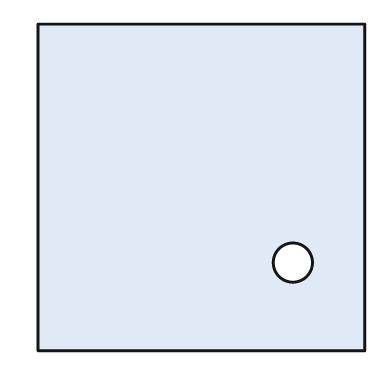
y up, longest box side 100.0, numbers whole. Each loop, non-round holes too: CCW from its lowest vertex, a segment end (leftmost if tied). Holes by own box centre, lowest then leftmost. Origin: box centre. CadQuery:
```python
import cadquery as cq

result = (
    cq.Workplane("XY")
    .moveTo(-50.0, -50.0)
    .lineTo(50.0, -50.0)
    .lineTo(50.0, 50.0)
    .lineTo(-50.0, 50.0)
    .close()
    .moveTo(28.0, -23.0)
    .circle(6.0)
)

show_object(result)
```